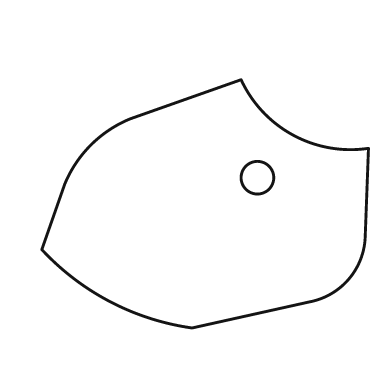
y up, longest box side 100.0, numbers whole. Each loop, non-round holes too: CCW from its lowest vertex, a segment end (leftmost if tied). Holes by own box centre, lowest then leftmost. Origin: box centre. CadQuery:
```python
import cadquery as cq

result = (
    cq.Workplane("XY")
    .moveTo(-4.0, -38.0)
    .lineTo(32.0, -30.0)
    .threePointArc((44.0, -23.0), (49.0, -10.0))
    .lineTo(50.0, 17.0)
    .threePointArc((27.0, 21.0), (11.0, 38.0))
    .lineTo(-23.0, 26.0)
    .threePointArc((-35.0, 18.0), (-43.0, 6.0))
    .lineTo(-50.0, -14.0)
    .threePointArc((-29.0, -30.0), (-4.0, -38.0))
    .close()
    .moveTo(16.0, 8.0)
    .circle(5.0)
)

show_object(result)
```